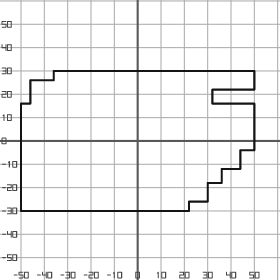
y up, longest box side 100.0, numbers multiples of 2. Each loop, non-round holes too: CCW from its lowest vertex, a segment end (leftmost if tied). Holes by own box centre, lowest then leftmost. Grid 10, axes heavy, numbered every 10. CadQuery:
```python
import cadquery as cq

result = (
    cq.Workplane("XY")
    .moveTo(-50.0, -30.0)
    .lineTo(22.0, -30.0)
    .lineTo(22.0, -26.0)
    .lineTo(30.0, -26.0)
    .lineTo(30.0, -18.0)
    .lineTo(36.0, -18.0)
    .lineTo(36.0, -12.0)
    .lineTo(44.0, -12.0)
    .lineTo(44.0, -4.0)
    .lineTo(50.0, -4.0)
    .lineTo(50.0, 16.0)
    .lineTo(32.0, 16.0)
    .lineTo(32.0, 22.0)
    .lineTo(50.0, 22.0)
    .lineTo(50.0, 30.0)
    .lineTo(-36.0, 30.0)
    .lineTo(-36.0, 26.0)
    .lineTo(-46.0, 26.0)
    .lineTo(-46.0, 16.0)
    .lineTo(-50.0, 16.0)
    .close()
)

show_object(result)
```